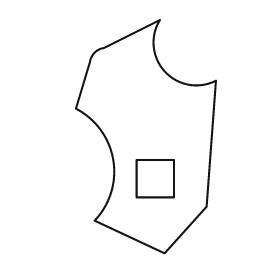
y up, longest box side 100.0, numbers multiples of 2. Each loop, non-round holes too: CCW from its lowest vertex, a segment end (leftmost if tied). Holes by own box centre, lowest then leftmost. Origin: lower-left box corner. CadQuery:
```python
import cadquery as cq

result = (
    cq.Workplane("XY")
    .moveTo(38.0, 0.0)
    .lineTo(56.0, 20.0)
    .lineTo(60.0, 74.0)
    .threePointArc((38.0, 78.0), (36.0, 100.0))
    .lineTo(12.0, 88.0)
    .threePointArc((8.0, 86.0), (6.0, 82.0))
    .lineTo(0.0, 62.0)
    .threePointArc((16.0, 40.0), (8.0, 14.0))
    .close()
    .moveTo(26.0, 24.0)
    .lineTo(42.0, 24.0)
    .lineTo(42.0, 40.0)
    .lineTo(26.0, 40.0)
    .close()
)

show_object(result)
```